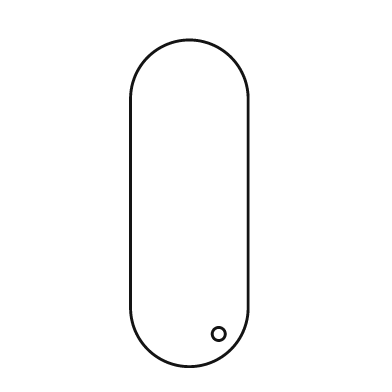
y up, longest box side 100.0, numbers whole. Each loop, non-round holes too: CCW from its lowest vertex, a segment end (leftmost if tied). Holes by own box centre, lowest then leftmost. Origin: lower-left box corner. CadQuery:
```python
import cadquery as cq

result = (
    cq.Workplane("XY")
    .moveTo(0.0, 18.0)
    .threePointArc((18.0, 0.0), (36.0, 18.0))
    .lineTo(36.0, 82.0)
    .threePointArc((18.0, 100.0), (0.0, 82.0))
    .close()
    .moveTo(27.0, 10.0)
    .circle(2.0)
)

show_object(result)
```